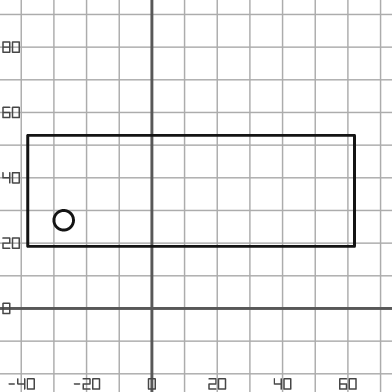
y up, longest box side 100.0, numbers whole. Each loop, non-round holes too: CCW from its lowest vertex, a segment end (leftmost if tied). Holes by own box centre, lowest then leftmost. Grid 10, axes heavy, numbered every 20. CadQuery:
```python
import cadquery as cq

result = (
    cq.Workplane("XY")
    .moveTo(-38.0, 19.0)
    .lineTo(62.0, 19.0)
    .lineTo(62.0, 53.0)
    .lineTo(-38.0, 53.0)
    .close()
    .moveTo(-27.0, 27.0)
    .circle(3.0)
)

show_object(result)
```